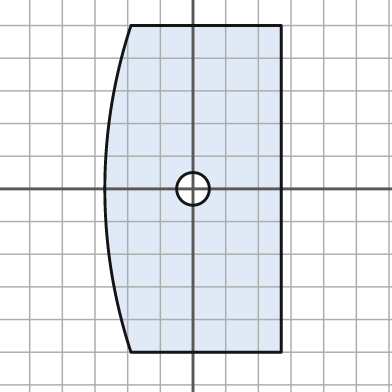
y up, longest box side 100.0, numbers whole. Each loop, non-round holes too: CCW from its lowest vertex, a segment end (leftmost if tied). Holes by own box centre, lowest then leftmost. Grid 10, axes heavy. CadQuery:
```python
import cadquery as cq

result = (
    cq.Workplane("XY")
    .moveTo(-19.0, -50.0)
    .lineTo(27.0, -50.0)
    .lineTo(27.0, 50.0)
    .lineTo(-19.0, 50.0)
    .threePointArc((-27.0, 0.0), (-19.0, -50.0))
    .close()
    .moveTo(0.0, 0.0)
    .circle(5.0)
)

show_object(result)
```